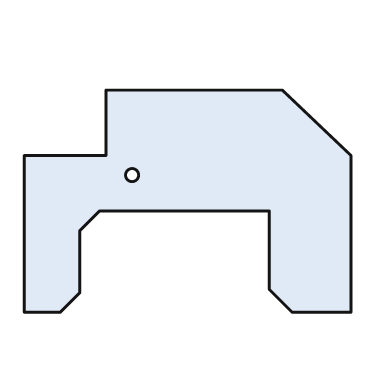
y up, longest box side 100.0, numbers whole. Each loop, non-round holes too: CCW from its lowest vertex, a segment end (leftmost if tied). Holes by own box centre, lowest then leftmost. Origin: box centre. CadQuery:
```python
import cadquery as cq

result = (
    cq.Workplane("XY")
    .moveTo(-50.0, -34.0)
    .lineTo(-39.0, -34.0)
    .lineTo(-33.0, -28.0)
    .lineTo(-33.0, -9.0)
    .lineTo(-27.0, -3.0)
    .lineTo(25.0, -3.0)
    .lineTo(25.0, -27.0)
    .lineTo(32.0, -34.0)
    .lineTo(50.0, -34.0)
    .lineTo(50.0, 14.0)
    .lineTo(29.0, 34.0)
    .lineTo(-25.0, 34.0)
    .lineTo(-25.0, 14.0)
    .lineTo(-50.0, 14.0)
    .close()
    .moveTo(-17.0, 8.0)
    .circle(2.0)
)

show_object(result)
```